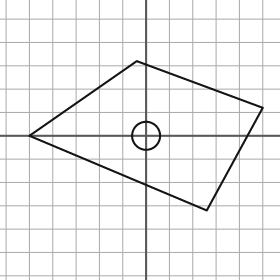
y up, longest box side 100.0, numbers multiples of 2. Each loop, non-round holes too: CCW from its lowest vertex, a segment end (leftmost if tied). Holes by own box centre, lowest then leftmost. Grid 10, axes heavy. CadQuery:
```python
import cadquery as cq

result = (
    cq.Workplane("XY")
    .moveTo(26.0, -32.0)
    .lineTo(50.0, 12.0)
    .lineTo(-4.0, 32.0)
    .lineTo(-50.0, 0.0)
    .close()
    .moveTo(0.0, 0.0)
    .circle(6.0)
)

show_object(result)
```